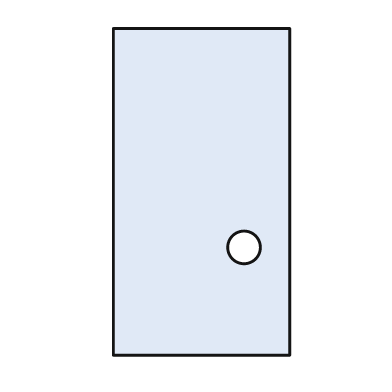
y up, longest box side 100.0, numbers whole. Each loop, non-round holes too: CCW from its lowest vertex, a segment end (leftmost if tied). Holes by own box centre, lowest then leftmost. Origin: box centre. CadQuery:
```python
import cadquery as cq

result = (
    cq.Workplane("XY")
    .moveTo(-27.0, -50.0)
    .lineTo(27.0, -50.0)
    .lineTo(27.0, 50.0)
    .lineTo(-27.0, 50.0)
    .close()
    .moveTo(13.0, -17.0)
    .circle(5.0)
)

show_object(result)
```